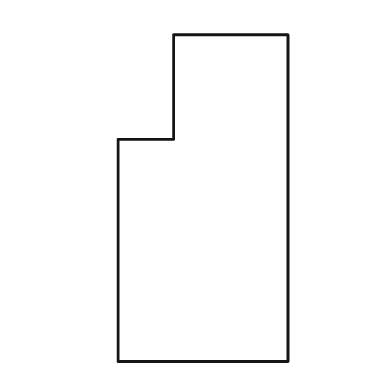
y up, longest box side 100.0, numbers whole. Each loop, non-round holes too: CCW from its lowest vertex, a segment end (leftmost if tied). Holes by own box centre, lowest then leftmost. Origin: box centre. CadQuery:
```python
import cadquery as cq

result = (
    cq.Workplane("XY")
    .moveTo(-26.0, -50.0)
    .lineTo(26.0, -50.0)
    .lineTo(26.0, 50.0)
    .lineTo(-9.0, 50.0)
    .lineTo(-9.0, 18.0)
    .lineTo(-26.0, 18.0)
    .close()
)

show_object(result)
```